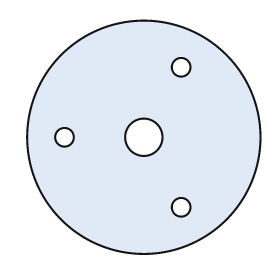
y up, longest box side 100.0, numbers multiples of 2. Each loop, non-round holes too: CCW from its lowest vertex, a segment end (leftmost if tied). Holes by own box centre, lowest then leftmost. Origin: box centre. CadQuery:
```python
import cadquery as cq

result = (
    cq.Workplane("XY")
    .moveTo(0.0, 0.0)
    .circle(50.0)
    .moveTo(16.0, -30.0)
    .circle(4.0)
    .moveTo(-34.0, 0.0)
    .circle(4.0)
    .moveTo(0.0, 0.0)
    .circle(8.0)
    .moveTo(16.0, 30.0)
    .circle(4.0)
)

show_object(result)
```